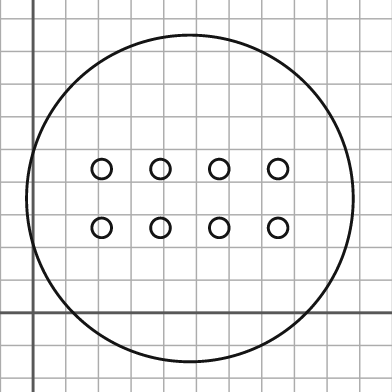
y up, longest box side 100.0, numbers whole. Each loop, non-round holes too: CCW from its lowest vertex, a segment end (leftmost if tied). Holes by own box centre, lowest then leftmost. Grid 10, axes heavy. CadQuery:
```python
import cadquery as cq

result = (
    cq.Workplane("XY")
    .moveTo(48.0, 35.0)
    .circle(50.0)
    .moveTo(21.0, 26.0)
    .circle(3.0)
    .moveTo(39.0, 26.0)
    .circle(3.0)
    .moveTo(57.0, 26.0)
    .circle(3.0)
    .moveTo(75.0, 26.0)
    .circle(3.0)
    .moveTo(21.0, 44.0)
    .circle(3.0)
    .moveTo(39.0, 44.0)
    .circle(3.0)
    .moveTo(57.0, 44.0)
    .circle(3.0)
    .moveTo(75.0, 44.0)
    .circle(3.0)
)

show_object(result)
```